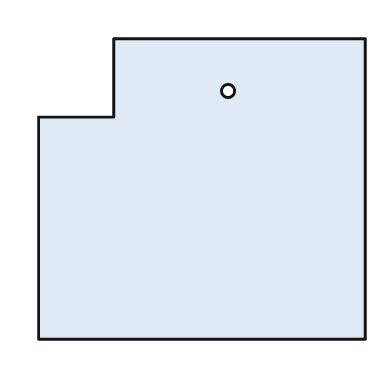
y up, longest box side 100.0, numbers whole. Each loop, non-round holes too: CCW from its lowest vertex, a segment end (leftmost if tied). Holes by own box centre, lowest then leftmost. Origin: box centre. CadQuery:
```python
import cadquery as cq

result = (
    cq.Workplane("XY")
    .moveTo(-50.0, -46.0)
    .lineTo(50.0, -46.0)
    .lineTo(50.0, 46.0)
    .lineTo(-27.0, 46.0)
    .lineTo(-27.0, 22.0)
    .lineTo(-50.0, 22.0)
    .close()
    .moveTo(8.0, 30.0)
    .circle(2.0)
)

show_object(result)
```